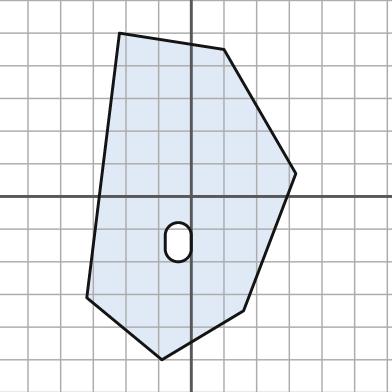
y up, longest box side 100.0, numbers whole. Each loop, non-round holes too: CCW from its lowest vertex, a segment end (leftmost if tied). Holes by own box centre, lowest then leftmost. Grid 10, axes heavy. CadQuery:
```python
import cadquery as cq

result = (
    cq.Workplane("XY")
    .moveTo(-9.0, -50.0)
    .lineTo(16.0, -35.0)
    .lineTo(32.0, 7.0)
    .lineTo(10.0, 45.0)
    .lineTo(-22.0, 50.0)
    .lineTo(-32.0, -31.0)
    .close()
    .moveTo(-8.0, -16.0)
    .threePointArc((-4.0, -20.0), (0.0, -16.0))
    .lineTo(0.0, -12.0)
    .threePointArc((-4.0, -8.0), (-8.0, -12.0))
    .close()
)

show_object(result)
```